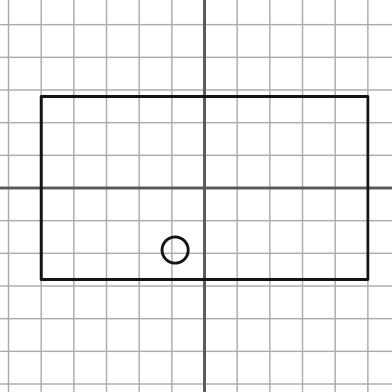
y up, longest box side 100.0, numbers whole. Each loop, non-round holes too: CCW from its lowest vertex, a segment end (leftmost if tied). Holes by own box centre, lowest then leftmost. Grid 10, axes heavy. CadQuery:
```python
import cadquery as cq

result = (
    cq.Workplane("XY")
    .moveTo(-50.0, -28.0)
    .lineTo(50.0, -28.0)
    .lineTo(50.0, 28.0)
    .lineTo(-50.0, 28.0)
    .close()
    .moveTo(-9.0, -19.0)
    .circle(4.0)
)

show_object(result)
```